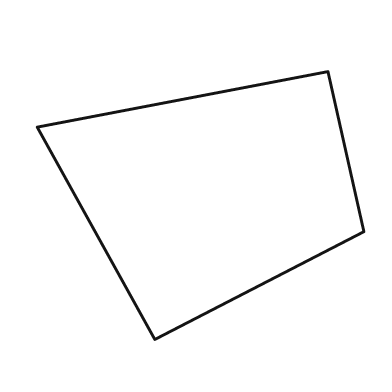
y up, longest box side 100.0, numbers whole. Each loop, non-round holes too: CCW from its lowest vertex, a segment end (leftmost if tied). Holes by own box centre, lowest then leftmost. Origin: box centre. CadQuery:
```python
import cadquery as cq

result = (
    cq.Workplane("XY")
    .moveTo(-14.0, -41.0)
    .lineTo(50.0, -8.0)
    .lineTo(39.0, 41.0)
    .lineTo(-50.0, 24.0)
    .close()
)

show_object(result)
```